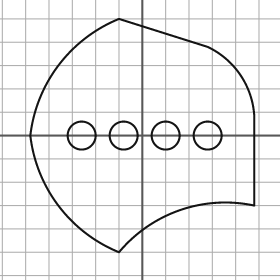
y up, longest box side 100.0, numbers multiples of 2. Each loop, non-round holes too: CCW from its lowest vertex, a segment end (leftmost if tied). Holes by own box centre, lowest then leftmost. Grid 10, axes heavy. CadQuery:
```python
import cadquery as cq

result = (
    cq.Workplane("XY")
    .moveTo(-10.0, -50.0)
    .threePointArc((16.0, -32.0), (48.0, -30.0))
    .lineTo(48.0, 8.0)
    .threePointArc((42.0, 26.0), (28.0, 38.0))
    .lineTo(-10.0, 50.0)
    .threePointArc((-36.0, 30.0), (-48.0, 0.0))
    .threePointArc((-36.0, -30.0), (-10.0, -50.0))
    .close()
    .moveTo(-26.0, 0.0)
    .circle(6.0)
    .moveTo(-8.0, 0.0)
    .circle(6.0)
    .moveTo(10.0, 0.0)
    .circle(6.0)
    .moveTo(28.0, 0.0)
    .circle(6.0)
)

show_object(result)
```